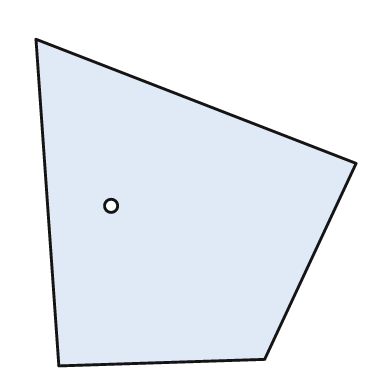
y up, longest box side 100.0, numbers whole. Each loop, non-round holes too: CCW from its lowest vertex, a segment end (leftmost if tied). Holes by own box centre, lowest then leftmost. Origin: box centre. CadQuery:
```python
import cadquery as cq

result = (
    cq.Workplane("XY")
    .moveTo(-42.0, -50.0)
    .lineTo(21.0, -48.0)
    .lineTo(49.0, 12.0)
    .lineTo(-49.0, 50.0)
    .close()
    .moveTo(-26.0, -1.0)
    .circle(2.0)
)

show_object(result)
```